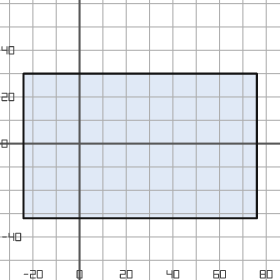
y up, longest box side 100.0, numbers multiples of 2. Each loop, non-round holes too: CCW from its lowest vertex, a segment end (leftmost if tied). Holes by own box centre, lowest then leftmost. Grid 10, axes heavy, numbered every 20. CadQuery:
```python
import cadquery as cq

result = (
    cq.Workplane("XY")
    .moveTo(-24.0, -32.0)
    .lineTo(76.0, -32.0)
    .lineTo(76.0, 30.0)
    .lineTo(-24.0, 30.0)
    .close()
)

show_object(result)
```